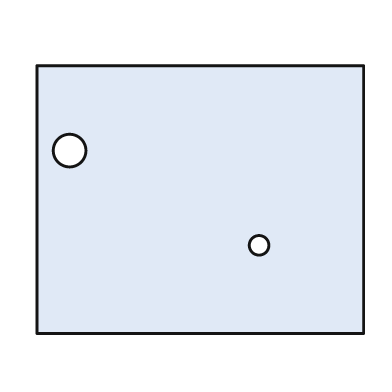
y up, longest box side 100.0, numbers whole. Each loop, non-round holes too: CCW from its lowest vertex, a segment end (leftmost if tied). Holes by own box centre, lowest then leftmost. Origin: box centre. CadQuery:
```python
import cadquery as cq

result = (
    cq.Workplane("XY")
    .moveTo(-50.0, -41.0)
    .lineTo(50.0, -41.0)
    .lineTo(50.0, 41.0)
    .lineTo(-50.0, 41.0)
    .close()
    .moveTo(18.0, -14.0)
    .circle(3.0)
    .moveTo(-40.0, 15.0)
    .circle(5.0)
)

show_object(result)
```